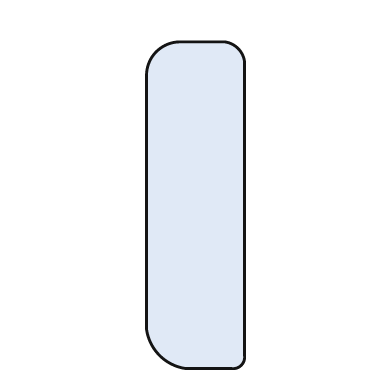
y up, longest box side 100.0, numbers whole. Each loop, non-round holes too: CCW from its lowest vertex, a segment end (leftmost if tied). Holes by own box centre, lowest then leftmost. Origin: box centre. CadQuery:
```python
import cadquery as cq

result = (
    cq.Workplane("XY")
    .moveTo(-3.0, -50.0)
    .lineTo(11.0, -50.0)
    .threePointArc((14.0, -49.0), (15.0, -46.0))
    .lineTo(15.0, 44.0)
    .threePointArc((13.0, 48.0), (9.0, 50.0))
    .lineTo(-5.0, 50.0)
    .threePointArc((-12.0, 47.0), (-15.0, 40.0))
    .lineTo(-15.0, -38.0)
    .threePointArc((-11.0, -46.0), (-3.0, -50.0))
    .close()
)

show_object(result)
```